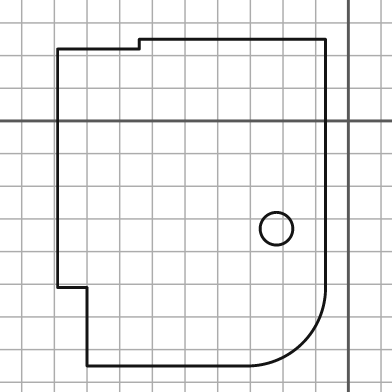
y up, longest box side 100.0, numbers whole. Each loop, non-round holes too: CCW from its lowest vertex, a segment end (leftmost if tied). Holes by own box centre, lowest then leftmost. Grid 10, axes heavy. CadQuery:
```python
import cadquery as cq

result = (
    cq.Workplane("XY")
    .moveTo(-80.0, -75.0)
    .lineTo(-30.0, -75.0)
    .threePointArc((-14.0, -68.0), (-7.0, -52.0))
    .lineTo(-7.0, 25.0)
    .lineTo(-64.0, 25.0)
    .lineTo(-64.0, 22.0)
    .lineTo(-89.0, 22.0)
    .lineTo(-89.0, -51.0)
    .lineTo(-80.0, -51.0)
    .close()
    .moveTo(-22.0, -33.0)
    .circle(5.0)
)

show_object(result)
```